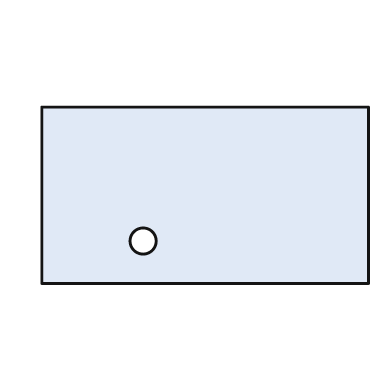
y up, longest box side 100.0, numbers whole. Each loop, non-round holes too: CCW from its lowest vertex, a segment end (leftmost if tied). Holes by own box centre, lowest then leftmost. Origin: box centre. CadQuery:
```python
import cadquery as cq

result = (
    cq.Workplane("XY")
    .moveTo(-50.0, -27.0)
    .lineTo(50.0, -27.0)
    .lineTo(50.0, 27.0)
    .lineTo(-50.0, 27.0)
    .close()
    .moveTo(-19.0, -14.0)
    .circle(4.0)
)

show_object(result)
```